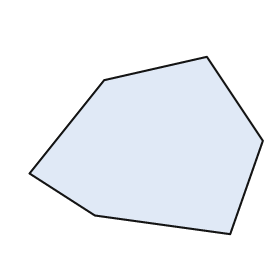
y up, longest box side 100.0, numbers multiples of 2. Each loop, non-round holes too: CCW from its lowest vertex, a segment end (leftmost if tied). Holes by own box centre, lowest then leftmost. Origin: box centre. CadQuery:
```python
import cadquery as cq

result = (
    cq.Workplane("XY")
    .moveTo(36.0, -38.0)
    .lineTo(50.0, 2.0)
    .lineTo(26.0, 38.0)
    .lineTo(-18.0, 28.0)
    .lineTo(-50.0, -12.0)
    .lineTo(-22.0, -30.0)
    .close()
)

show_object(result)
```